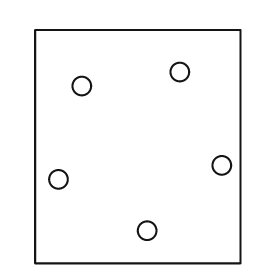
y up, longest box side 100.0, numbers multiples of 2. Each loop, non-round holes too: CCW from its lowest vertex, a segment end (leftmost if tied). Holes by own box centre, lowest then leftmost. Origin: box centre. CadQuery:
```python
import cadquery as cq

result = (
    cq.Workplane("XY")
    .moveTo(-44.0, -50.0)
    .lineTo(44.0, -50.0)
    .lineTo(44.0, 50.0)
    .lineTo(-44.0, 50.0)
    .close()
    .moveTo(4.0, -36.0)
    .circle(4.0)
    .moveTo(-34.0, -14.0)
    .circle(4.0)
    .moveTo(36.0, -8.0)
    .circle(4.0)
    .moveTo(-24.0, 26.0)
    .circle(4.0)
    .moveTo(18.0, 32.0)
    .circle(4.0)
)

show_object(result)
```